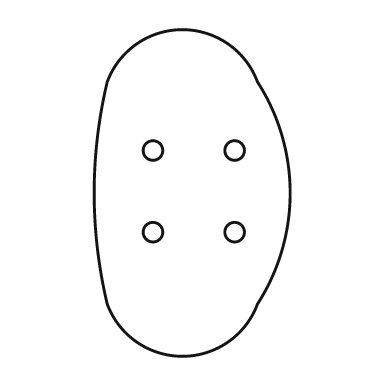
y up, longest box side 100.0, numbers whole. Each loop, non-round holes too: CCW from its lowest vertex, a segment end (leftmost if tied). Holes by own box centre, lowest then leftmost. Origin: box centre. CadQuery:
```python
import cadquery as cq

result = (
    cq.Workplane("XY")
    .moveTo(-26.0, -34.0)
    .threePointArc((-3.0, -50.0), (20.0, -34.0))
    .threePointArc((30.0, 0.0), (20.0, 34.0))
    .threePointArc((-3.0, 50.0), (-26.0, 34.0))
    .threePointArc((-30.0, 0.0), (-26.0, -34.0))
    .close()
    .moveTo(-12.0, -12.0)
    .circle(3.0)
    .moveTo(13.0, -12.0)
    .circle(3.0)
    .moveTo(-12.0, 13.0)
    .circle(3.0)
    .moveTo(13.0, 13.0)
    .circle(3.0)
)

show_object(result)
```